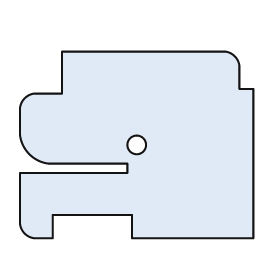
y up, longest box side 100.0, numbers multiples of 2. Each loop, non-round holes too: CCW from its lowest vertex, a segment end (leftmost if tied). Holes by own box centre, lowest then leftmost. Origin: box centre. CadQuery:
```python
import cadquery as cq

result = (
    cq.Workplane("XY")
    .moveTo(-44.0, -40.0)
    .lineTo(-36.0, -40.0)
    .lineTo(-36.0, -30.0)
    .lineTo(-2.0, -30.0)
    .lineTo(-2.0, -40.0)
    .lineTo(50.0, -40.0)
    .lineTo(50.0, 24.0)
    .lineTo(44.0, 24.0)
    .lineTo(44.0, 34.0)
    .threePointArc((42.0, 38.0), (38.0, 40.0))
    .lineTo(-32.0, 40.0)
    .lineTo(-32.0, 22.0)
    .lineTo(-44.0, 22.0)
    .threePointArc((-48.0, 20.0), (-50.0, 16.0))
    .lineTo(-50.0, 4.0)
    .threePointArc((-46.0, -4.0), (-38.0, -8.0))
    .lineTo(-4.0, -8.0)
    .lineTo(-4.0, -12.0)
    .lineTo(-50.0, -12.0)
    .lineTo(-50.0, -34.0)
    .threePointArc((-48.0, -38.0), (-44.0, -40.0))
    .close()
    .moveTo(0.0, 0.0)
    .circle(4.0)
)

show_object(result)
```